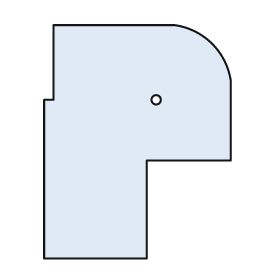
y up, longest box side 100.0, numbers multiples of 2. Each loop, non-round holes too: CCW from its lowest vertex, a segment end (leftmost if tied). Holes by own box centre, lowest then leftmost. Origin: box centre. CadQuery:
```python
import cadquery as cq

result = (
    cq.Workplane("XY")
    .moveTo(-40.0, -50.0)
    .lineTo(4.0, -50.0)
    .lineTo(4.0, -8.0)
    .lineTo(40.0, -8.0)
    .lineTo(40.0, 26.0)
    .threePointArc((32.0, 42.0), (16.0, 50.0))
    .lineTo(-36.0, 50.0)
    .lineTo(-36.0, 18.0)
    .lineTo(-40.0, 18.0)
    .close()
    .moveTo(8.0, 18.0)
    .circle(2.0)
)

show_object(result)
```